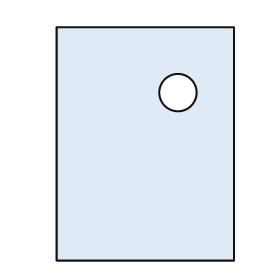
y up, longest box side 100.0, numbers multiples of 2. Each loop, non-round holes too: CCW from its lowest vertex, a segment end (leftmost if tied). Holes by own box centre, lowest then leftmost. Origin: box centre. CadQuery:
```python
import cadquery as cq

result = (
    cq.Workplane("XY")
    .moveTo(-38.0, -50.0)
    .lineTo(38.0, -50.0)
    .lineTo(38.0, 50.0)
    .lineTo(-38.0, 50.0)
    .close()
    .moveTo(14.0, 22.0)
    .circle(8.0)
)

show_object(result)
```